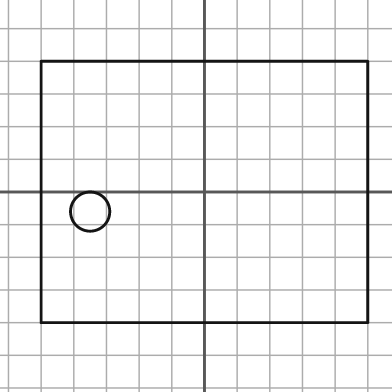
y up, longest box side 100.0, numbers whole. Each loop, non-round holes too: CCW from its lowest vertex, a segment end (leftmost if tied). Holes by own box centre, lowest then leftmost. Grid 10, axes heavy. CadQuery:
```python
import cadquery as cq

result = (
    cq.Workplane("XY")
    .moveTo(-50.0, -40.0)
    .lineTo(50.0, -40.0)
    .lineTo(50.0, 40.0)
    .lineTo(-50.0, 40.0)
    .close()
    .moveTo(-35.0, -6.0)
    .circle(6.0)
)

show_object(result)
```